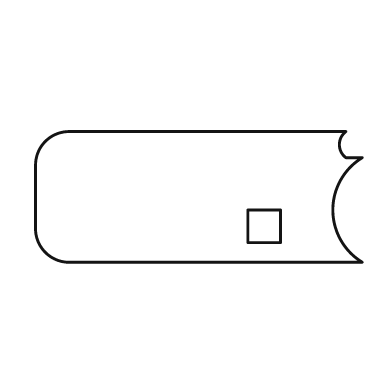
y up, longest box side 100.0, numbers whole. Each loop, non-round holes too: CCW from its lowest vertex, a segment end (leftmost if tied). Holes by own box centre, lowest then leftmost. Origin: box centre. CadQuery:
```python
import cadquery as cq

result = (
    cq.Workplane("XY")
    .moveTo(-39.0, -20.0)
    .lineTo(50.0, -20.0)
    .threePointArc((41.0, -4.0), (50.0, 12.0))
    .lineTo(45.0, 12.0)
    .threePointArc((43.0, 16.0), (45.0, 20.0))
    .lineTo(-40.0, 20.0)
    .threePointArc((-47.0, 17.0), (-50.0, 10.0))
    .lineTo(-50.0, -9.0)
    .threePointArc((-47.0, -17.0), (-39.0, -20.0))
    .close()
    .moveTo(15.0, -14.0)
    .lineTo(25.0, -14.0)
    .lineTo(25.0, -4.0)
    .lineTo(15.0, -4.0)
    .close()
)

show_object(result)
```